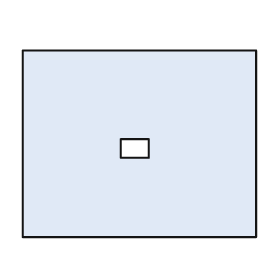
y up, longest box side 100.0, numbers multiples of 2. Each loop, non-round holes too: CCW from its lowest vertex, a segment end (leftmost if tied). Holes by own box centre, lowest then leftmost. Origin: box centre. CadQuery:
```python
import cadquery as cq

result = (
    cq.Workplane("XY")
    .moveTo(-50.0, -40.0)
    .lineTo(50.0, -40.0)
    .lineTo(50.0, 40.0)
    .lineTo(-50.0, 40.0)
    .close()
    .moveTo(-8.0, -6.0)
    .lineTo(4.0, -6.0)
    .lineTo(4.0, 2.0)
    .lineTo(-8.0, 2.0)
    .close()
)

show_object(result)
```